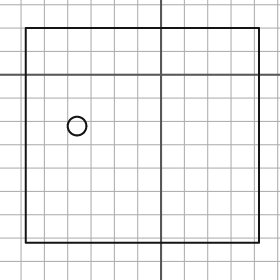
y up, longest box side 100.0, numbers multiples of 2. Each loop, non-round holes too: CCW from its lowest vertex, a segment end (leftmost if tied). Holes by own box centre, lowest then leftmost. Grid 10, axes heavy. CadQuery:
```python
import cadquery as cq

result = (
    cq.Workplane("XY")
    .moveTo(-58.0, -72.0)
    .lineTo(42.0, -72.0)
    .lineTo(42.0, 20.0)
    .lineTo(-58.0, 20.0)
    .close()
    .moveTo(-36.0, -22.0)
    .circle(4.0)
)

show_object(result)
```